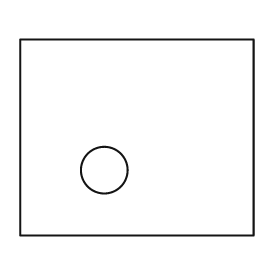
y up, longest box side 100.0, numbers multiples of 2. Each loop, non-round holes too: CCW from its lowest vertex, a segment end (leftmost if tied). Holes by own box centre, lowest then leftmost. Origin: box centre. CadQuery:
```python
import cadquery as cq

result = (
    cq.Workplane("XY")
    .moveTo(-50.0, -42.0)
    .lineTo(50.0, -42.0)
    .lineTo(50.0, 42.0)
    .lineTo(-50.0, 42.0)
    .close()
    .moveTo(-14.0, -14.0)
    .circle(10.0)
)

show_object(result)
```